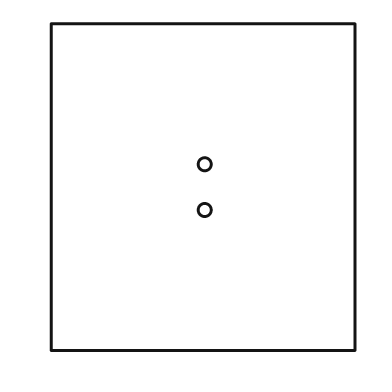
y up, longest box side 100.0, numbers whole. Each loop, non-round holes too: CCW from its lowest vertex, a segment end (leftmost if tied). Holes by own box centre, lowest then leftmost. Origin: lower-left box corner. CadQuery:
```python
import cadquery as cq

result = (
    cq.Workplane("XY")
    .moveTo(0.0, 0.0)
    .lineTo(93.0, 0.0)
    .lineTo(93.0, 100.0)
    .lineTo(0.0, 100.0)
    .close()
    .moveTo(47.0, 43.0)
    .circle(2.0)
    .moveTo(47.0, 57.0)
    .circle(2.0)
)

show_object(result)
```